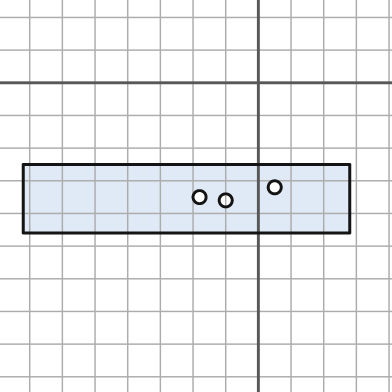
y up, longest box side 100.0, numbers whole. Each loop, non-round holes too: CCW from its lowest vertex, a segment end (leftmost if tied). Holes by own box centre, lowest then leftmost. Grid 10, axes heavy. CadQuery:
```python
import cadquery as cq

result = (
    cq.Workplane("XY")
    .moveTo(-72.0, -46.0)
    .lineTo(28.0, -46.0)
    .lineTo(28.0, -25.0)
    .lineTo(-72.0, -25.0)
    .close()
    .moveTo(-10.0, -36.0)
    .circle(2.0)
    .moveTo(-18.0, -35.0)
    .circle(2.0)
    .moveTo(5.0, -32.0)
    .circle(2.0)
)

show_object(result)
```